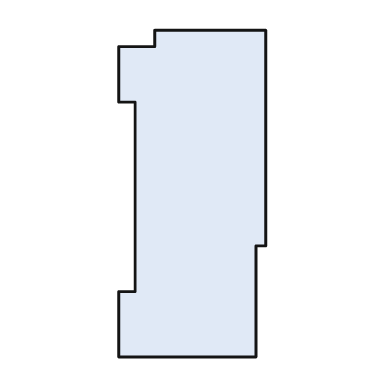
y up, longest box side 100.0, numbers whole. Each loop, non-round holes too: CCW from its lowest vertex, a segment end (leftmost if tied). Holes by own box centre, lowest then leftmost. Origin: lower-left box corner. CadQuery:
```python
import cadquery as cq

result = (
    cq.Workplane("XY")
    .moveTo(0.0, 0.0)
    .lineTo(42.0, 0.0)
    .lineTo(42.0, 34.0)
    .lineTo(45.0, 34.0)
    .lineTo(45.0, 100.0)
    .lineTo(11.0, 100.0)
    .lineTo(11.0, 95.0)
    .lineTo(0.0, 95.0)
    .lineTo(0.0, 78.0)
    .lineTo(5.0, 78.0)
    .lineTo(5.0, 20.0)
    .lineTo(0.0, 20.0)
    .close()
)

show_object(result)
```